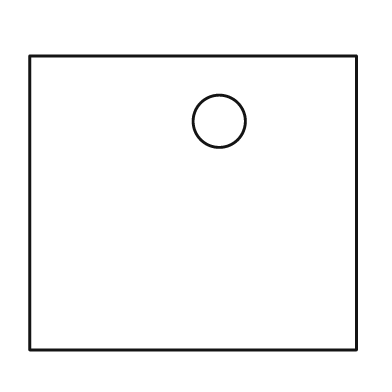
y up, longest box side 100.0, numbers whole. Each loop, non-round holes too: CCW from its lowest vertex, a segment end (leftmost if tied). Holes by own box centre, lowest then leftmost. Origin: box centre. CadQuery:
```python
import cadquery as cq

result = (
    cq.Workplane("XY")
    .moveTo(-50.0, -45.0)
    .lineTo(50.0, -45.0)
    .lineTo(50.0, 45.0)
    .lineTo(-50.0, 45.0)
    .close()
    .moveTo(8.0, 25.0)
    .circle(8.0)
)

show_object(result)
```